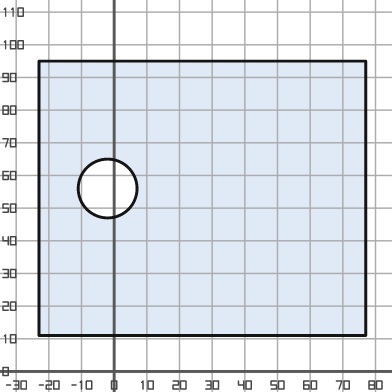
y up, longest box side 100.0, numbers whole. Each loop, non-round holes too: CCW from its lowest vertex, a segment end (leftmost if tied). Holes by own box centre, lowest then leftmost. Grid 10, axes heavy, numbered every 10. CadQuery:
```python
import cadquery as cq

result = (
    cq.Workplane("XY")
    .moveTo(-23.0, 11.0)
    .lineTo(77.0, 11.0)
    .lineTo(77.0, 95.0)
    .lineTo(-23.0, 95.0)
    .close()
    .moveTo(-2.0, 56.0)
    .circle(9.0)
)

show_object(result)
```